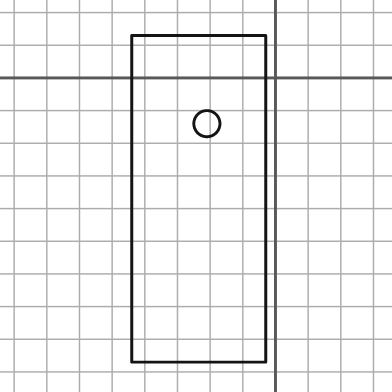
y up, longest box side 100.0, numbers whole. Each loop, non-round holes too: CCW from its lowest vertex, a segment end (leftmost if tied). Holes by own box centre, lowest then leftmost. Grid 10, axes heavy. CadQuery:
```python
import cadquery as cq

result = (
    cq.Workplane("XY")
    .moveTo(-44.0, -87.0)
    .lineTo(-3.0, -87.0)
    .lineTo(-3.0, 13.0)
    .lineTo(-44.0, 13.0)
    .close()
    .moveTo(-21.0, -14.0)
    .circle(4.0)
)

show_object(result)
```